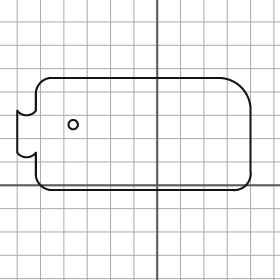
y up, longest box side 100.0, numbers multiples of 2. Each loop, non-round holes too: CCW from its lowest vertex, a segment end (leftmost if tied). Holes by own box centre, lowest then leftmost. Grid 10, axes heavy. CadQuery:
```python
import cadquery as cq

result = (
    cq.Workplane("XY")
    .moveTo(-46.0, -2.0)
    .lineTo(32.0, -2.0)
    .threePointArc((38.0, 0.0), (40.0, 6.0))
    .lineTo(40.0, 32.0)
    .threePointArc((36.0, 42.0), (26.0, 46.0))
    .lineTo(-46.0, 46.0)
    .threePointArc((-50.0, 44.0), (-52.0, 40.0))
    .lineTo(-52.0, 32.0)
    .threePointArc((-56.0, 30.0), (-60.0, 32.0))
    .lineTo(-60.0, 14.0)
    .threePointArc((-56.0, 12.0), (-52.0, 14.0))
    .lineTo(-52.0, 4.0)
    .threePointArc((-50.0, 0.0), (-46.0, -2.0))
    .close()
    .moveTo(-36.0, 26.0)
    .circle(2.0)
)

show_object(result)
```